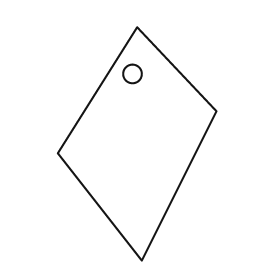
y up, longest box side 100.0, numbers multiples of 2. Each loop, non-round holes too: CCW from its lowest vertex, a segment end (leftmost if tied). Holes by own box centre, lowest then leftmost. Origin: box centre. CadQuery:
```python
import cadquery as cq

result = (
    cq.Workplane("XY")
    .moveTo(2.0, -50.0)
    .lineTo(34.0, 14.0)
    .lineTo(0.0, 50.0)
    .lineTo(-34.0, -4.0)
    .close()
    .moveTo(-2.0, 30.0)
    .circle(4.0)
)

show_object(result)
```